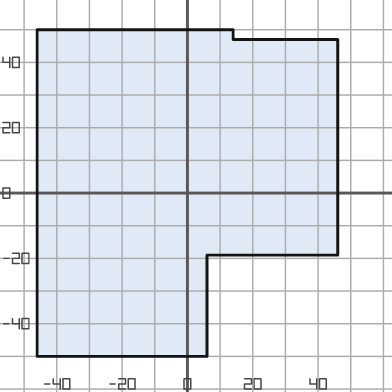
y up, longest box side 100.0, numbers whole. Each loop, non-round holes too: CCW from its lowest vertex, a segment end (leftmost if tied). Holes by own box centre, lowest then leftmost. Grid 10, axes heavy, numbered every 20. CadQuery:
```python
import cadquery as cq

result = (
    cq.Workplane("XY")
    .moveTo(-46.0, -50.0)
    .lineTo(6.0, -50.0)
    .lineTo(6.0, -19.0)
    .lineTo(46.0, -19.0)
    .lineTo(46.0, 47.0)
    .lineTo(14.0, 47.0)
    .lineTo(14.0, 50.0)
    .lineTo(-46.0, 50.0)
    .close()
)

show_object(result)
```